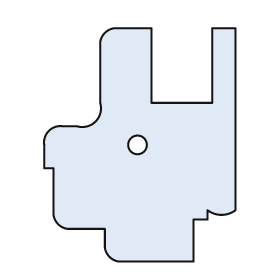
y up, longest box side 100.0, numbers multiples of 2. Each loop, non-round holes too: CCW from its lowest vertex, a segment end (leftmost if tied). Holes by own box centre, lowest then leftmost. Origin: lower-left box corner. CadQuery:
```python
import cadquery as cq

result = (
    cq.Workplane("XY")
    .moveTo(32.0, 0.0)
    .lineTo(64.0, 0.0)
    .lineTo(64.0, 18.0)
    .lineTo(70.0, 18.0)
    .lineTo(70.0, 22.0)
    .threePointArc((76.0, 20.0), (82.0, 22.0))
    .lineTo(82.0, 100.0)
    .lineTo(72.0, 100.0)
    .lineTo(72.0, 68.0)
    .lineTo(46.0, 68.0)
    .lineTo(46.0, 100.0)
    .lineTo(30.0, 100.0)
    .threePointArc((26.0, 98.0), (24.0, 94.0))
    .lineTo(24.0, 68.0)
    .threePointArc((22.0, 60.0), (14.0, 58.0))
    .lineTo(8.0, 58.0)
    .threePointArc((2.0, 56.0), (0.0, 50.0))
    .lineTo(0.0, 40.0)
    .lineTo(4.0, 40.0)
    .lineTo(4.0, 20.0)
    .threePointArc((6.0, 16.0), (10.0, 14.0))
    .lineTo(26.0, 14.0)
    .lineTo(26.0, 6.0)
    .threePointArc((28.0, 2.0), (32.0, 0.0))
    .close()
    .moveTo(40.0, 50.0)
    .circle(4.0)
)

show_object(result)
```